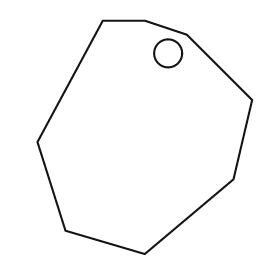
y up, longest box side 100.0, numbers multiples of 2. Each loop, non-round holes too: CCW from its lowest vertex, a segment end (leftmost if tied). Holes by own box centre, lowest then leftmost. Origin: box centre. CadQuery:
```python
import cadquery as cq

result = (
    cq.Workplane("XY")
    .moveTo(0.0, -50.0)
    .lineTo(38.0, -18.0)
    .lineTo(46.0, 16.0)
    .lineTo(18.0, 44.0)
    .lineTo(0.0, 50.0)
    .lineTo(-18.0, 50.0)
    .lineTo(-46.0, -2.0)
    .lineTo(-34.0, -40.0)
    .close()
    .moveTo(10.0, 36.0)
    .circle(6.0)
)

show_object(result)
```